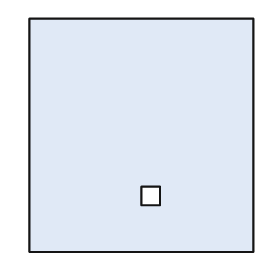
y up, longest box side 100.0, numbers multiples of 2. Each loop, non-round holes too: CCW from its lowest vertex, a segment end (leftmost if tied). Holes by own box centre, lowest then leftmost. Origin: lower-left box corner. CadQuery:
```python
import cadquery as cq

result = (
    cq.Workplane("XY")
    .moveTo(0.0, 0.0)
    .lineTo(96.0, 0.0)
    .lineTo(96.0, 100.0)
    .lineTo(0.0, 100.0)
    .close()
    .moveTo(48.0, 20.0)
    .lineTo(56.0, 20.0)
    .lineTo(56.0, 28.0)
    .lineTo(48.0, 28.0)
    .close()
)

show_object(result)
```